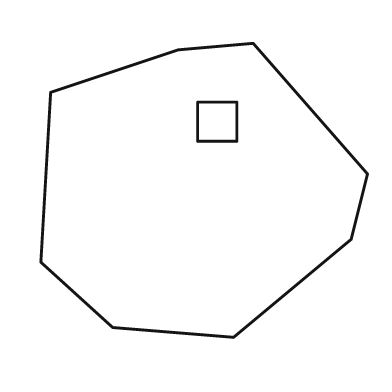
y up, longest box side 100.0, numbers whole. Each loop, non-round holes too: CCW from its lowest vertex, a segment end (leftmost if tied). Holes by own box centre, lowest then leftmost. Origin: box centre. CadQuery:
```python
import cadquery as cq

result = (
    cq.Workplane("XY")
    .moveTo(9.0, -45.0)
    .lineTo(45.0, -15.0)
    .lineTo(50.0, 5.0)
    .lineTo(15.0, 45.0)
    .lineTo(-8.0, 43.0)
    .lineTo(-47.0, 30.0)
    .lineTo(-50.0, -22.0)
    .lineTo(-28.0, -42.0)
    .close()
    .moveTo(-2.0, 15.0)
    .lineTo(10.0, 15.0)
    .lineTo(10.0, 27.0)
    .lineTo(-2.0, 27.0)
    .close()
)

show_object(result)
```